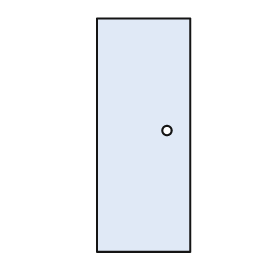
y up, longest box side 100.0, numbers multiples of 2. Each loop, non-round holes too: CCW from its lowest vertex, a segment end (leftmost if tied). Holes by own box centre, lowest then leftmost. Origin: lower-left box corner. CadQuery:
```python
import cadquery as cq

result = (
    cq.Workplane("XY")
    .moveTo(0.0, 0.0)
    .lineTo(40.0, 0.0)
    .lineTo(40.0, 100.0)
    .lineTo(0.0, 100.0)
    .close()
    .moveTo(30.0, 52.0)
    .circle(2.0)
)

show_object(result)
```